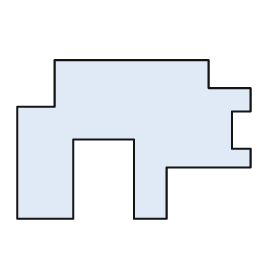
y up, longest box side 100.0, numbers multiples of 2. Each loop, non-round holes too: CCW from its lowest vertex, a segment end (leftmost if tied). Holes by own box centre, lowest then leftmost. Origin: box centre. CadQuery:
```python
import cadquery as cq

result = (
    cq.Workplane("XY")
    .moveTo(-50.0, -34.0)
    .lineTo(-26.0, -34.0)
    .lineTo(-26.0, 0.0)
    .lineTo(0.0, 0.0)
    .lineTo(0.0, -34.0)
    .lineTo(14.0, -34.0)
    .lineTo(14.0, -12.0)
    .lineTo(50.0, -12.0)
    .lineTo(50.0, -4.0)
    .lineTo(42.0, -4.0)
    .lineTo(42.0, 12.0)
    .lineTo(50.0, 12.0)
    .lineTo(50.0, 22.0)
    .lineTo(32.0, 22.0)
    .lineTo(32.0, 34.0)
    .lineTo(-34.0, 34.0)
    .lineTo(-34.0, 14.0)
    .lineTo(-50.0, 14.0)
    .close()
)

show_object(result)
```